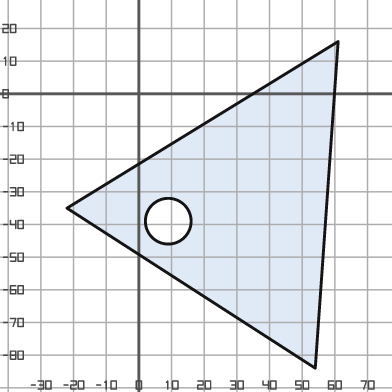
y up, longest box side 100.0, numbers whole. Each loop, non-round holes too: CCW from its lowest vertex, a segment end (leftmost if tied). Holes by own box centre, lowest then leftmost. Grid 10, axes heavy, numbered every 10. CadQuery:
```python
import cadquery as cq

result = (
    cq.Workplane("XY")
    .moveTo(54.0, -84.0)
    .lineTo(61.0, 16.0)
    .lineTo(-22.0, -35.0)
    .close()
    .moveTo(9.0, -39.0)
    .circle(7.0)
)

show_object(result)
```